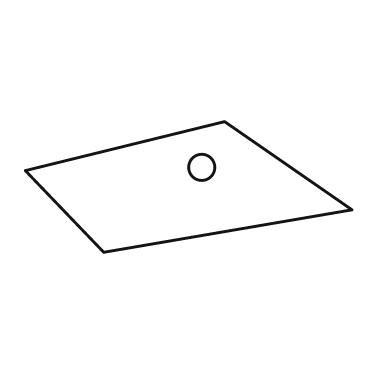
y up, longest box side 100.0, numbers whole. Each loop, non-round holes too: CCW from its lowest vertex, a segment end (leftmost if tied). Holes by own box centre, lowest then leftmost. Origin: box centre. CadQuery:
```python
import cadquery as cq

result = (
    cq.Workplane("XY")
    .moveTo(-26.0, -20.0)
    .lineTo(50.0, -7.0)
    .lineTo(11.0, 20.0)
    .lineTo(-50.0, 5.0)
    .close()
    .moveTo(4.0, 6.0)
    .circle(4.0)
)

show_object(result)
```